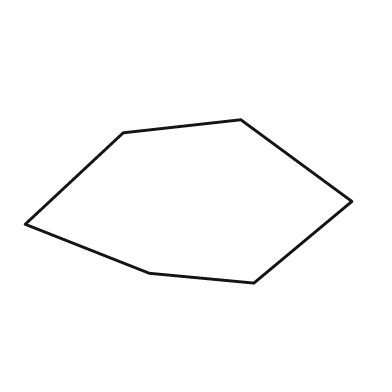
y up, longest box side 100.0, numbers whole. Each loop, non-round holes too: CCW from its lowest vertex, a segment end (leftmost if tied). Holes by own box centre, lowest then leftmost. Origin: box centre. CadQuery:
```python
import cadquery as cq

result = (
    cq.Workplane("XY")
    .moveTo(20.0, -25.0)
    .lineTo(50.0, 0.0)
    .lineTo(16.0, 25.0)
    .lineTo(-20.0, 21.0)
    .lineTo(-50.0, -7.0)
    .lineTo(-12.0, -22.0)
    .close()
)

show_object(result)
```